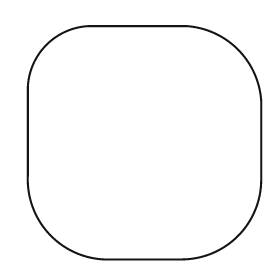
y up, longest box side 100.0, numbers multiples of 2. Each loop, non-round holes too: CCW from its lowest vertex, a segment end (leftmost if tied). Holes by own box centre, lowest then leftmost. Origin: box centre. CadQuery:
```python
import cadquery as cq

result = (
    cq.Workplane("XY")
    .moveTo(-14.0, -50.0)
    .lineTo(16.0, -50.0)
    .threePointArc((40.0, -40.0), (50.0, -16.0))
    .lineTo(50.0, 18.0)
    .threePointArc((40.0, 40.0), (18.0, 50.0))
    .lineTo(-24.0, 50.0)
    .threePointArc((-42.0, 42.0), (-50.0, 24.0))
    .lineTo(-50.0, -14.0)
    .threePointArc((-40.0, -40.0), (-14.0, -50.0))
    .close()
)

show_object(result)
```